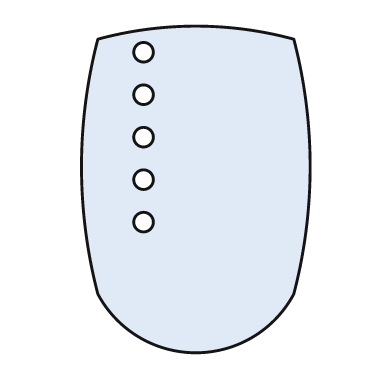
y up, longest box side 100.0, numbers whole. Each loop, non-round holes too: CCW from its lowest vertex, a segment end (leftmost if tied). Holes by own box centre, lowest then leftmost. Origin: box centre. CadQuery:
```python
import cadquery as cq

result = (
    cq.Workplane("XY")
    .moveTo(-30.0, -32.0)
    .threePointArc((0.0, -50.0), (30.0, -32.0))
    .threePointArc((35.0, 7.0), (30.0, 46.0))
    .threePointArc((0.0, 50.0), (-30.0, 46.0))
    .threePointArc((-35.0, 7.0), (-30.0, -32.0))
    .close()
    .moveTo(-16.0, -10.0)
    .circle(3.0)
    .moveTo(-16.0, 3.0)
    .circle(3.0)
    .moveTo(-16.0, 16.0)
    .circle(3.0)
    .moveTo(-16.0, 29.0)
    .circle(3.0)
    .moveTo(-16.0, 42.0)
    .circle(3.0)
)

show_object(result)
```